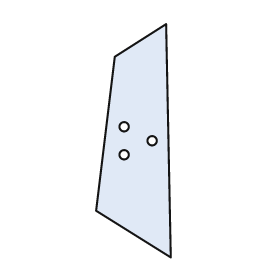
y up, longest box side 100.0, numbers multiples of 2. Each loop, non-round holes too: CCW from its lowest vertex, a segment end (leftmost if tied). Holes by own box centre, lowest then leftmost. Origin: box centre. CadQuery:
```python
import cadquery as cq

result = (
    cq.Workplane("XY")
    .moveTo(16.0, -50.0)
    .lineTo(14.0, 50.0)
    .lineTo(-8.0, 36.0)
    .lineTo(-16.0, -30.0)
    .close()
    .moveTo(-4.0, -6.0)
    .circle(2.0)
    .moveTo(8.0, 0.0)
    .circle(2.0)
    .moveTo(-4.0, 6.0)
    .circle(2.0)
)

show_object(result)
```